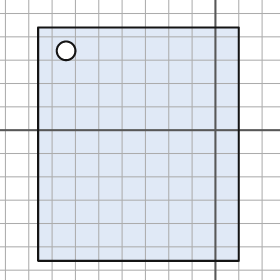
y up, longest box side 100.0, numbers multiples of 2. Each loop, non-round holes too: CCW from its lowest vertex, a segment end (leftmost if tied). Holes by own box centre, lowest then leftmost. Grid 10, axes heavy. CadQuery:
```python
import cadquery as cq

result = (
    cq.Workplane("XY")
    .moveTo(-76.0, -56.0)
    .lineTo(10.0, -56.0)
    .lineTo(10.0, 44.0)
    .lineTo(-76.0, 44.0)
    .close()
    .moveTo(-64.0, 34.0)
    .circle(4.0)
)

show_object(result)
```